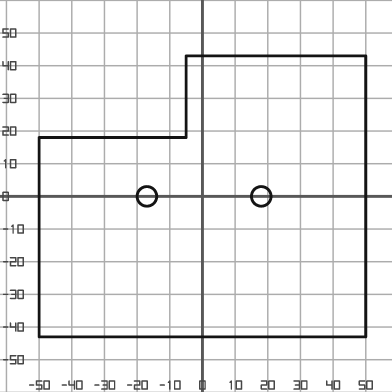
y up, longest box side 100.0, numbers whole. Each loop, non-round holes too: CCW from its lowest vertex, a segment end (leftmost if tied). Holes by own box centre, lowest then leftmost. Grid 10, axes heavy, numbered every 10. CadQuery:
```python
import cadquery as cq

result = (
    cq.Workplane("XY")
    .moveTo(-50.0, -43.0)
    .lineTo(50.0, -43.0)
    .lineTo(50.0, 43.0)
    .lineTo(-5.0, 43.0)
    .lineTo(-5.0, 18.0)
    .lineTo(-50.0, 18.0)
    .close()
    .moveTo(-17.0, 0.0)
    .circle(3.0)
    .moveTo(18.0, 0.0)
    .circle(3.0)
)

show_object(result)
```